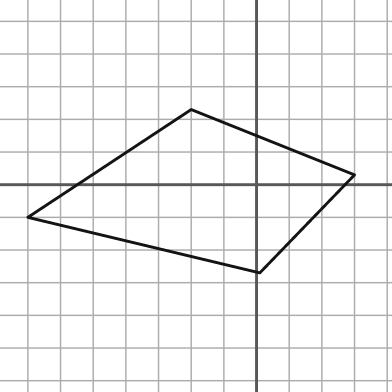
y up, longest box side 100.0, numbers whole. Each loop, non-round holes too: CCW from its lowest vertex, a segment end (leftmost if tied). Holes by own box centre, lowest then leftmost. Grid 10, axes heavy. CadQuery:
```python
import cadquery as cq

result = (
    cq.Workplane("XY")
    .moveTo(1.0, -27.0)
    .lineTo(30.0, 3.0)
    .lineTo(-20.0, 23.0)
    .lineTo(-70.0, -10.0)
    .close()
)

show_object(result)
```